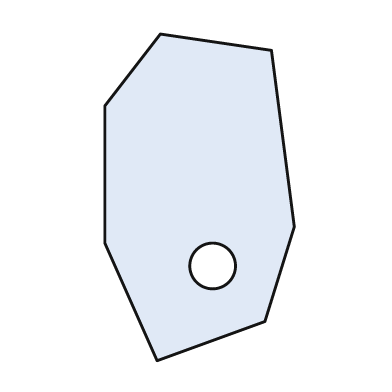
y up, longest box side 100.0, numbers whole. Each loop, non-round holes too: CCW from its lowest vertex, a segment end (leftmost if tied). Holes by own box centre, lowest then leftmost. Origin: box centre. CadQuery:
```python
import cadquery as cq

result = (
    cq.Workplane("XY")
    .moveTo(-13.0, -50.0)
    .lineTo(20.0, -38.0)
    .lineTo(29.0, -9.0)
    .lineTo(22.0, 45.0)
    .lineTo(-12.0, 50.0)
    .lineTo(-29.0, 28.0)
    .lineTo(-29.0, -14.0)
    .close()
    .moveTo(4.0, -21.0)
    .circle(7.0)
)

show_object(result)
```